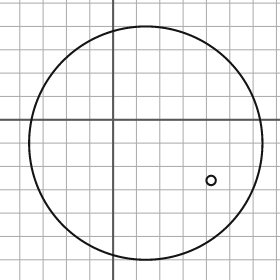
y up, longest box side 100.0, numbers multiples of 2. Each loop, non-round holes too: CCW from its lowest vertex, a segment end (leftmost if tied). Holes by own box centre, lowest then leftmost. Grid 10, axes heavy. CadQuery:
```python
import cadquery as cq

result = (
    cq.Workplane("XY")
    .moveTo(14.0, -10.0)
    .circle(50.0)
    .moveTo(42.0, -26.0)
    .circle(2.0)
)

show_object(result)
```